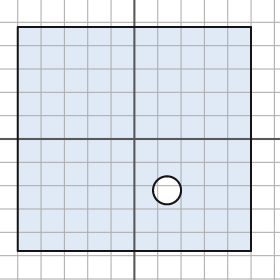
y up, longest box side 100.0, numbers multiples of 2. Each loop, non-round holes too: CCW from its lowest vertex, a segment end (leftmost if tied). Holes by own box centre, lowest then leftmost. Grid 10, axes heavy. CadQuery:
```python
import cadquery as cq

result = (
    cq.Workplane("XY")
    .moveTo(-50.0, -48.0)
    .lineTo(50.0, -48.0)
    .lineTo(50.0, 48.0)
    .lineTo(-50.0, 48.0)
    .close()
    .moveTo(14.0, -22.0)
    .circle(6.0)
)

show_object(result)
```